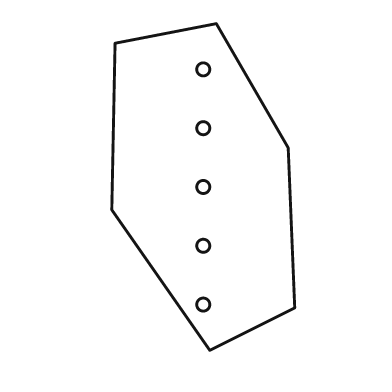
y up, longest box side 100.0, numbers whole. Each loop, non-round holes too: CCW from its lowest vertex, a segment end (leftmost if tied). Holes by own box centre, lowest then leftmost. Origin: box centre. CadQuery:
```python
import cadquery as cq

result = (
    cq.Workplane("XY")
    .moveTo(2.0, -50.0)
    .lineTo(28.0, -37.0)
    .lineTo(26.0, 12.0)
    .lineTo(4.0, 50.0)
    .lineTo(-27.0, 44.0)
    .lineTo(-28.0, -7.0)
    .close()
    .moveTo(0.0, -36.0)
    .circle(2.0)
    .moveTo(0.0, -18.0)
    .circle(2.0)
    .moveTo(0.0, 0.0)
    .circle(2.0)
    .moveTo(0.0, 18.0)
    .circle(2.0)
    .moveTo(0.0, 36.0)
    .circle(2.0)
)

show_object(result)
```